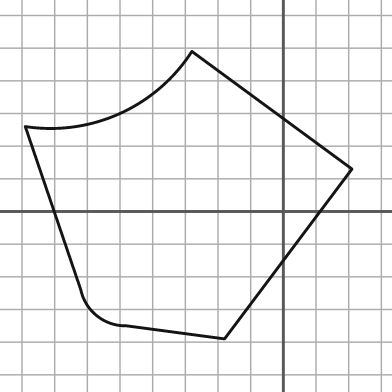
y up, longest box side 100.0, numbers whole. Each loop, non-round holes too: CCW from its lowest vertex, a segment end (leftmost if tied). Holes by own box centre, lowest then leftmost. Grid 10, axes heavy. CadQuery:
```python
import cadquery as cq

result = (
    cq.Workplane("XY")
    .moveTo(-18.0, -39.0)
    .lineTo(21.0, 13.0)
    .lineTo(-28.0, 49.0)
    .threePointArc((-50.0, 30.0), (-79.0, 26.0))
    .lineTo(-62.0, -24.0)
    .threePointArc((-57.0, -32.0), (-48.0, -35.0))
    .close()
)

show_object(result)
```